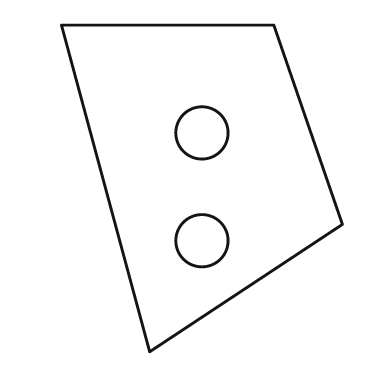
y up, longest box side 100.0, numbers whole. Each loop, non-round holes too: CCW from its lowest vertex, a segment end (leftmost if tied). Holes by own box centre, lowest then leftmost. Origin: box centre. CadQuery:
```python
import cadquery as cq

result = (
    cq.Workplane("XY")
    .moveTo(-16.0, -50.0)
    .lineTo(43.0, -11.0)
    .lineTo(22.0, 50.0)
    .lineTo(-43.0, 50.0)
    .close()
    .moveTo(0.0, -16.0)
    .circle(8.0)
    .moveTo(0.0, 17.0)
    .circle(8.0)
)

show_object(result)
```